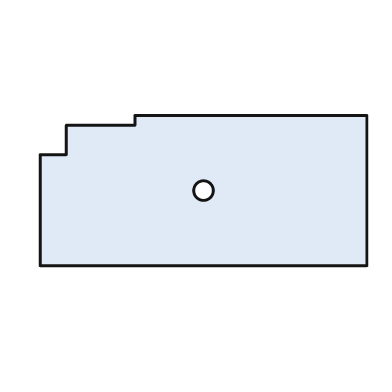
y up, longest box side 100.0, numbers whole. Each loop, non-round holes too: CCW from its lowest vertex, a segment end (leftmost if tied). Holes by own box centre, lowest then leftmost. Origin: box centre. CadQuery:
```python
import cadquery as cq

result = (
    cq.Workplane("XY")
    .moveTo(-50.0, -23.0)
    .lineTo(50.0, -23.0)
    .lineTo(50.0, 23.0)
    .lineTo(-21.0, 23.0)
    .lineTo(-21.0, 20.0)
    .lineTo(-42.0, 20.0)
    .lineTo(-42.0, 11.0)
    .lineTo(-50.0, 11.0)
    .close()
    .moveTo(0.0, 0.0)
    .circle(3.0)
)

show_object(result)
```